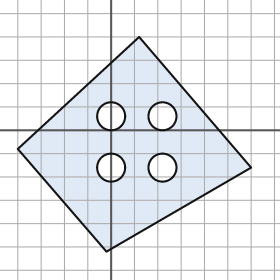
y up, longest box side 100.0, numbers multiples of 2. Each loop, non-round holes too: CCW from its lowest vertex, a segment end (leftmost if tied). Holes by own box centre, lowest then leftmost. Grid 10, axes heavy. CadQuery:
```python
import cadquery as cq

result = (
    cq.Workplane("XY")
    .moveTo(-2.0, -52.0)
    .lineTo(60.0, -16.0)
    .lineTo(12.0, 40.0)
    .lineTo(-40.0, -8.0)
    .close()
    .moveTo(0.0, -16.0)
    .circle(6.0)
    .moveTo(22.0, -16.0)
    .circle(6.0)
    .moveTo(0.0, 6.0)
    .circle(6.0)
    .moveTo(22.0, 6.0)
    .circle(6.0)
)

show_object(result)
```